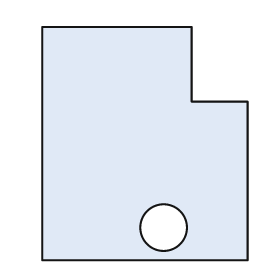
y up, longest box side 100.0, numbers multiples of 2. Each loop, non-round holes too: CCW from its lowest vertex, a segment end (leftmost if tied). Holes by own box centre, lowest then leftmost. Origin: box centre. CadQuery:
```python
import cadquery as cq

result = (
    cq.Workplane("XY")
    .moveTo(-44.0, -50.0)
    .lineTo(44.0, -50.0)
    .lineTo(44.0, 18.0)
    .lineTo(20.0, 18.0)
    .lineTo(20.0, 50.0)
    .lineTo(-44.0, 50.0)
    .close()
    .moveTo(8.0, -36.0)
    .circle(10.0)
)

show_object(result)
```